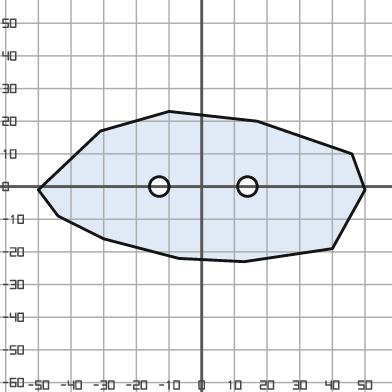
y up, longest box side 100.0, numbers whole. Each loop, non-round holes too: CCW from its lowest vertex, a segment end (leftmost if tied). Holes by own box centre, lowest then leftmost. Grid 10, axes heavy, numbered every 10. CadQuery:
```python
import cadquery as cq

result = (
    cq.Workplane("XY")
    .moveTo(13.0, -23.0)
    .lineTo(40.0, -19.0)
    .lineTo(50.0, -1.0)
    .lineTo(46.0, 10.0)
    .lineTo(17.0, 20.0)
    .lineTo(-10.0, 23.0)
    .lineTo(-31.0, 17.0)
    .lineTo(-50.0, -1.0)
    .lineTo(-44.0, -9.0)
    .lineTo(-30.0, -16.0)
    .lineTo(-7.0, -22.0)
    .close()
    .moveTo(-13.0, 0.0)
    .circle(3.0)
    .moveTo(14.0, 0.0)
    .circle(3.0)
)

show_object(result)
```